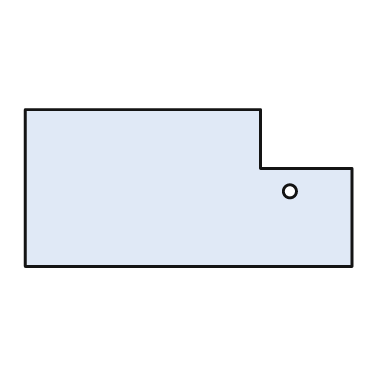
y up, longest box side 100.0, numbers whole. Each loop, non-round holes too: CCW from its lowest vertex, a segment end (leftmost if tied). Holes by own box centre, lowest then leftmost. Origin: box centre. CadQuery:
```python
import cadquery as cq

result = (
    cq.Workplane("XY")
    .moveTo(-50.0, -24.0)
    .lineTo(50.0, -24.0)
    .lineTo(50.0, 6.0)
    .lineTo(22.0, 6.0)
    .lineTo(22.0, 24.0)
    .lineTo(-50.0, 24.0)
    .close()
    .moveTo(31.0, -1.0)
    .circle(2.0)
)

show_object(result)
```